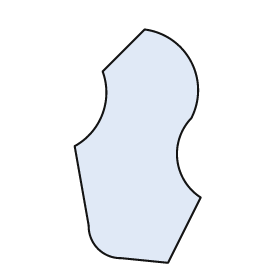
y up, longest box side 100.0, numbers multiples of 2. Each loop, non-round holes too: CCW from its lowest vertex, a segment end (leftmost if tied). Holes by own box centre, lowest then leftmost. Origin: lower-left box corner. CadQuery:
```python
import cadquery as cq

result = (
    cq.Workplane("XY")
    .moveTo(40.0, 0.0)
    .lineTo(54.0, 28.0)
    .threePointArc((44.0, 44.0), (50.0, 62.0))
    .threePointArc((50.0, 86.0), (30.0, 100.0))
    .lineTo(12.0, 82.0)
    .threePointArc((12.0, 64.0), (0.0, 50.0))
    .lineTo(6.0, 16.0)
    .threePointArc((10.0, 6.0), (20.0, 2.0))
    .close()
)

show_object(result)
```